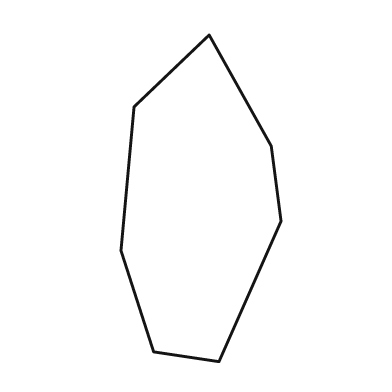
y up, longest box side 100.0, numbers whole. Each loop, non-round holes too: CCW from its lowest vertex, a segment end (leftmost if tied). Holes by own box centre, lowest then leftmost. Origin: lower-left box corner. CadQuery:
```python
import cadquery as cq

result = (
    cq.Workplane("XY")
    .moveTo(30.0, 0.0)
    .lineTo(49.0, 43.0)
    .lineTo(46.0, 66.0)
    .lineTo(27.0, 100.0)
    .lineTo(4.0, 78.0)
    .lineTo(0.0, 34.0)
    .lineTo(10.0, 3.0)
    .close()
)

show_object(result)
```